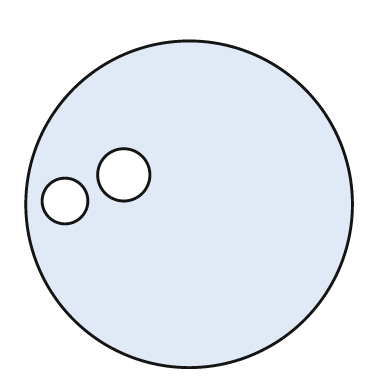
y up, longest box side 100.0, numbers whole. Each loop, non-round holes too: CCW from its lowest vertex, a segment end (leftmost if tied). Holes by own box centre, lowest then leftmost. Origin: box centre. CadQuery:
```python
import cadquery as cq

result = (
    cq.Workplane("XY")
    .moveTo(0.0, 0.0)
    .circle(50.0)
    .moveTo(-38.0, 1.0)
    .circle(7.0)
    .moveTo(-20.0, 9.0)
    .circle(8.0)
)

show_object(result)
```